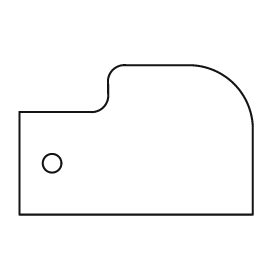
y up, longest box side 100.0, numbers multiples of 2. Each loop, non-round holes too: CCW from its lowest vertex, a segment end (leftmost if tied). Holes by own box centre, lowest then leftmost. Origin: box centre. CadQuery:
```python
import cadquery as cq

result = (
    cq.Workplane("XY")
    .moveTo(-50.0, -32.0)
    .lineTo(50.0, -32.0)
    .lineTo(50.0, 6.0)
    .threePointArc((42.0, 24.0), (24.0, 32.0))
    .lineTo(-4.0, 32.0)
    .threePointArc((-10.0, 30.0), (-12.0, 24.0))
    .lineTo(-12.0, 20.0)
    .threePointArc((-14.0, 14.0), (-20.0, 12.0))
    .lineTo(-50.0, 12.0)
    .close()
    .moveTo(-36.0, -10.0)
    .circle(4.0)
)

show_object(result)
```